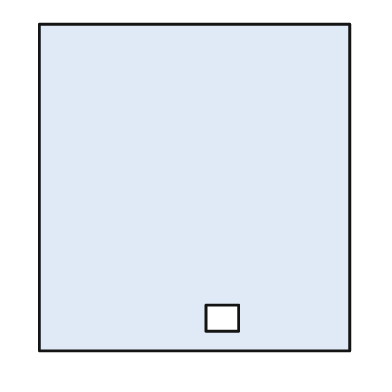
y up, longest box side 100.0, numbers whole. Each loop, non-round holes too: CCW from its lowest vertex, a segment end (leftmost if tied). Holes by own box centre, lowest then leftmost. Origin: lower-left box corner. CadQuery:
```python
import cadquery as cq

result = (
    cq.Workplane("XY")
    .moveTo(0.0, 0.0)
    .lineTo(95.0, 0.0)
    .lineTo(95.0, 100.0)
    .lineTo(0.0, 100.0)
    .close()
    .moveTo(51.0, 6.0)
    .lineTo(61.0, 6.0)
    .lineTo(61.0, 14.0)
    .lineTo(51.0, 14.0)
    .close()
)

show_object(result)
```